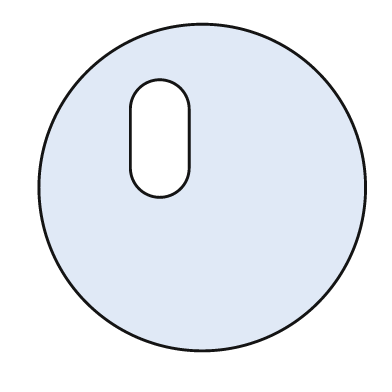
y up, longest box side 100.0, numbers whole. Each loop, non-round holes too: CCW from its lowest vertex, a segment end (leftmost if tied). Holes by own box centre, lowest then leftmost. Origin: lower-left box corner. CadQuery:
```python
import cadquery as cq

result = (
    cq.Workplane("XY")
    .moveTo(50.0, 50.0)
    .circle(50.0)
    .moveTo(28.0, 56.0)
    .threePointArc((37.0, 47.0), (46.0, 56.0))
    .lineTo(46.0, 74.0)
    .threePointArc((37.0, 83.0), (28.0, 74.0))
    .close()
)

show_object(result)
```